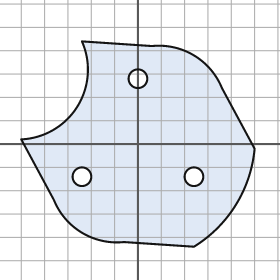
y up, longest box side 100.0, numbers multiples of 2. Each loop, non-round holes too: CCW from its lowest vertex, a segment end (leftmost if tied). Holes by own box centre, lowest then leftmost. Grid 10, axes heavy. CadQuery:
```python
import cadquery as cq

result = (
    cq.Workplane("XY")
    .moveTo(24.0, -44.0)
    .threePointArc((42.0, -26.0), (50.0, -2.0))
    .lineTo(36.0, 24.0)
    .threePointArc((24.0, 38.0), (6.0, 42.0))
    .lineTo(-24.0, 44.0)
    .threePointArc((-26.0, 16.0), (-50.0, 2.0))
    .lineTo(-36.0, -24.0)
    .threePointArc((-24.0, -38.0), (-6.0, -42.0))
    .close()
    .moveTo(-24.0, -14.0)
    .circle(4.0)
    .moveTo(24.0, -14.0)
    .circle(4.0)
    .moveTo(0.0, 28.0)
    .circle(4.0)
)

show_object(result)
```